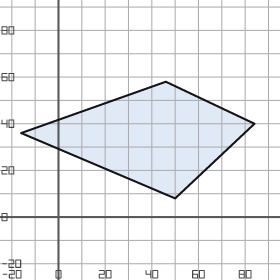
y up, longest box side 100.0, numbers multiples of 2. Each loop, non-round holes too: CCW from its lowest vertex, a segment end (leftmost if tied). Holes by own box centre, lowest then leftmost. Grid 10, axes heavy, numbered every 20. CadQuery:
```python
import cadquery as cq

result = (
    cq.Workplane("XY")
    .moveTo(50.0, 8.0)
    .lineTo(84.0, 40.0)
    .lineTo(46.0, 58.0)
    .lineTo(-16.0, 36.0)
    .close()
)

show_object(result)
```